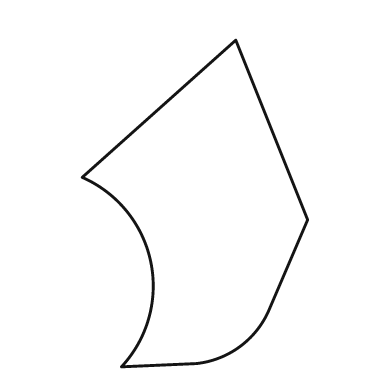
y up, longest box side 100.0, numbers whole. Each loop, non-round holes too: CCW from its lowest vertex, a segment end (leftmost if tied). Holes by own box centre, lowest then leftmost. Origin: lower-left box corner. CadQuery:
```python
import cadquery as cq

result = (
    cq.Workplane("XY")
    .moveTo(12.0, 0.0)
    .lineTo(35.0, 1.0)
    .threePointArc((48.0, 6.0), (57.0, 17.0))
    .lineTo(69.0, 45.0)
    .lineTo(47.0, 100.0)
    .lineTo(0.0, 58.0)
    .threePointArc((21.0, 32.0), (12.0, 0.0))
    .close()
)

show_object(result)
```